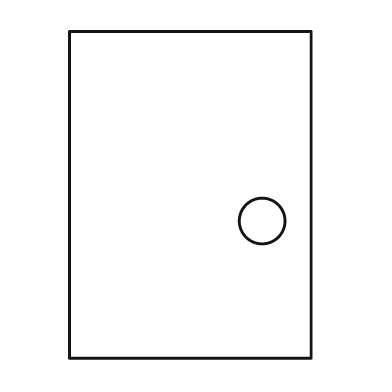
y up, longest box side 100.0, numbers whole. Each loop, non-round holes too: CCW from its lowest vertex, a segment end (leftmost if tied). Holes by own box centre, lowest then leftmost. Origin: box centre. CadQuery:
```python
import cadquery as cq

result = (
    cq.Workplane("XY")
    .moveTo(-37.0, -50.0)
    .lineTo(37.0, -50.0)
    .lineTo(37.0, 50.0)
    .lineTo(-37.0, 50.0)
    .close()
    .moveTo(22.0, -8.0)
    .circle(7.0)
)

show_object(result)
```